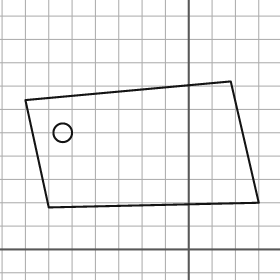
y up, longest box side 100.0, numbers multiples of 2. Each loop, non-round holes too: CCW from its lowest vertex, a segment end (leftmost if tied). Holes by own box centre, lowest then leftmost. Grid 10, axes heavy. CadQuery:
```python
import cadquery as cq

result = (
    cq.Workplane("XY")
    .moveTo(-60.0, 18.0)
    .lineTo(30.0, 20.0)
    .lineTo(18.0, 72.0)
    .lineTo(-70.0, 64.0)
    .close()
    .moveTo(-54.0, 50.0)
    .circle(4.0)
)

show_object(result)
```